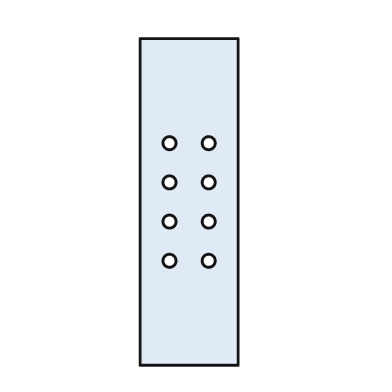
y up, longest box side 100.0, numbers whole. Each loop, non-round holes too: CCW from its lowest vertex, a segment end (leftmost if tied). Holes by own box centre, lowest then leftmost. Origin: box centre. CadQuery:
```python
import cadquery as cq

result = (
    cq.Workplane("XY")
    .moveTo(-15.0, -50.0)
    .lineTo(15.0, -50.0)
    .lineTo(15.0, 50.0)
    .lineTo(-15.0, 50.0)
    .close()
    .moveTo(-6.0, -18.0)
    .circle(2.0)
    .moveTo(6.0, -18.0)
    .circle(2.0)
    .moveTo(-6.0, -6.0)
    .circle(2.0)
    .moveTo(6.0, -6.0)
    .circle(2.0)
    .moveTo(-6.0, 6.0)
    .circle(2.0)
    .moveTo(6.0, 6.0)
    .circle(2.0)
    .moveTo(-6.0, 18.0)
    .circle(2.0)
    .moveTo(6.0, 18.0)
    .circle(2.0)
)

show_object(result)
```